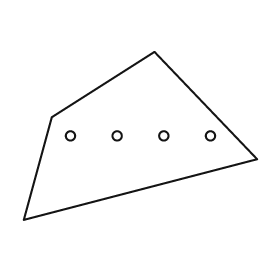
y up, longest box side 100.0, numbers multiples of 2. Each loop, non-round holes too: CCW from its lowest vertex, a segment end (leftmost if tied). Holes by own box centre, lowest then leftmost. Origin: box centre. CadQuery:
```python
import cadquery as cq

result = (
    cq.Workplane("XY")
    .moveTo(-50.0, -36.0)
    .lineTo(50.0, -10.0)
    .lineTo(6.0, 36.0)
    .lineTo(-38.0, 8.0)
    .close()
    .moveTo(-30.0, 0.0)
    .circle(2.0)
    .moveTo(-10.0, 0.0)
    .circle(2.0)
    .moveTo(10.0, 0.0)
    .circle(2.0)
    .moveTo(30.0, 0.0)
    .circle(2.0)
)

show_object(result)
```